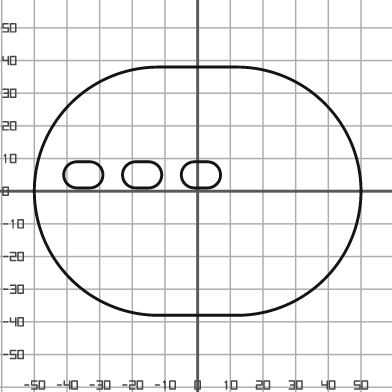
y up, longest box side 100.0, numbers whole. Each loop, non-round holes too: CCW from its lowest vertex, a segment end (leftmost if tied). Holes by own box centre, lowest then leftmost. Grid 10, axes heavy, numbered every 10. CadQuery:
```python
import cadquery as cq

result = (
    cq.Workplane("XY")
    .moveTo(-12.0, -38.0)
    .lineTo(12.0, -38.0)
    .threePointArc((50.0, 0.0), (12.0, 38.0))
    .lineTo(-12.0, 38.0)
    .threePointArc((-50.0, 0.0), (-12.0, -38.0))
    .close()
    .moveTo(-37.0, 1.0)
    .lineTo(-33.0, 1.0)
    .threePointArc((-29.0, 5.0), (-33.0, 9.0))
    .lineTo(-37.0, 9.0)
    .threePointArc((-41.0, 5.0), (-37.0, 1.0))
    .close()
    .moveTo(-19.0, 1.0)
    .lineTo(-15.0, 1.0)
    .threePointArc((-11.0, 5.0), (-15.0, 9.0))
    .lineTo(-19.0, 9.0)
    .threePointArc((-23.0, 5.0), (-19.0, 1.0))
    .close()
    .moveTo(-1.0, 1.0)
    .lineTo(3.0, 1.0)
    .threePointArc((7.0, 5.0), (3.0, 9.0))
    .lineTo(-1.0, 9.0)
    .threePointArc((-5.0, 5.0), (-1.0, 1.0))
    .close()
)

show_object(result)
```